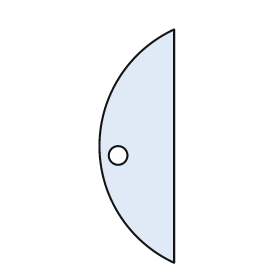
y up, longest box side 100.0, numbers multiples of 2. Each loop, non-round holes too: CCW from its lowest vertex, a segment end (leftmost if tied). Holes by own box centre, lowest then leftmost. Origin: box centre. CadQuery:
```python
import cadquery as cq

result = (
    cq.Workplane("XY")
    .moveTo(16.0, -50.0)
    .lineTo(16.0, 50.0)
    .threePointArc((-16.0, 0.0), (16.0, -50.0))
    .close()
    .moveTo(-8.0, -4.0)
    .circle(4.0)
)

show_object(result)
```